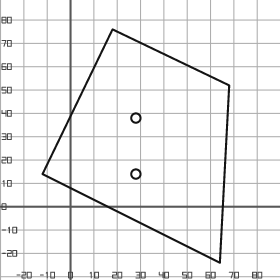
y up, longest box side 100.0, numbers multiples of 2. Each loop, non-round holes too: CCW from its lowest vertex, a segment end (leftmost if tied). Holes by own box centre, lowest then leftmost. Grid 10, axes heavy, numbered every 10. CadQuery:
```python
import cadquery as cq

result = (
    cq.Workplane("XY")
    .moveTo(64.0, -24.0)
    .lineTo(68.0, 52.0)
    .lineTo(18.0, 76.0)
    .lineTo(-12.0, 14.0)
    .close()
    .moveTo(28.0, 14.0)
    .circle(2.0)
    .moveTo(28.0, 38.0)
    .circle(2.0)
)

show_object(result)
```